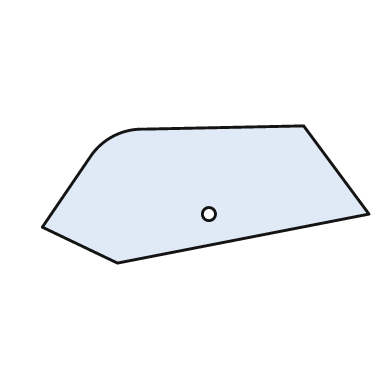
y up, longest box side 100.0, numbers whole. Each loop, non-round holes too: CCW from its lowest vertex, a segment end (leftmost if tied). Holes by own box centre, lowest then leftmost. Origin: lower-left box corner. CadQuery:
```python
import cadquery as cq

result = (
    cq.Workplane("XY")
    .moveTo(23.0, 0.0)
    .lineTo(100.0, 15.0)
    .lineTo(80.0, 42.0)
    .lineTo(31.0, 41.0)
    .threePointArc((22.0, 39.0), (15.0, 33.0))
    .lineTo(0.0, 11.0)
    .close()
    .moveTo(51.0, 15.0)
    .circle(2.0)
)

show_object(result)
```